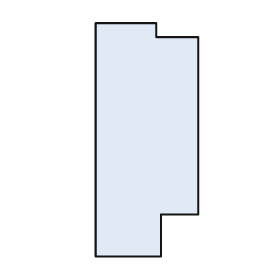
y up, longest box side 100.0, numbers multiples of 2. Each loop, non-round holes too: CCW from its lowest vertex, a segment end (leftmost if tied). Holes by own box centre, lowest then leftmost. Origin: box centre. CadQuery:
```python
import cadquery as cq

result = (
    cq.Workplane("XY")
    .moveTo(-22.0, -50.0)
    .lineTo(6.0, -50.0)
    .lineTo(6.0, -32.0)
    .lineTo(22.0, -32.0)
    .lineTo(22.0, 44.0)
    .lineTo(4.0, 44.0)
    .lineTo(4.0, 50.0)
    .lineTo(-22.0, 50.0)
    .close()
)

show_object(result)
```